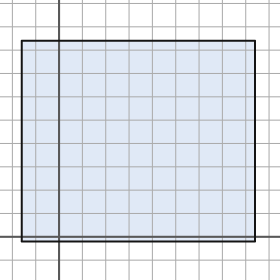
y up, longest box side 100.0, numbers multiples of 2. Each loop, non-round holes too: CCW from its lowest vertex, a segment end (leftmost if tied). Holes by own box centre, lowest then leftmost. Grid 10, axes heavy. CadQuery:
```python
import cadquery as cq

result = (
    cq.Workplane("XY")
    .moveTo(-16.0, -2.0)
    .lineTo(84.0, -2.0)
    .lineTo(84.0, 84.0)
    .lineTo(-16.0, 84.0)
    .close()
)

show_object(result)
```